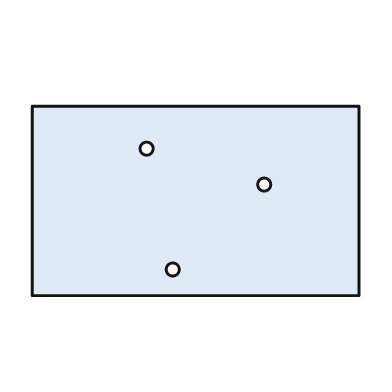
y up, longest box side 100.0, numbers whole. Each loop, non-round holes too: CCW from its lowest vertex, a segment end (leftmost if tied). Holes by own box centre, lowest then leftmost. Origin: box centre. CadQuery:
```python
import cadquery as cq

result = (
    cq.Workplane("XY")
    .moveTo(-50.0, -29.0)
    .lineTo(50.0, -29.0)
    .lineTo(50.0, 29.0)
    .lineTo(-50.0, 29.0)
    .close()
    .moveTo(-7.0, -21.0)
    .circle(2.0)
    .moveTo(21.0, 5.0)
    .circle(2.0)
    .moveTo(-15.0, 16.0)
    .circle(2.0)
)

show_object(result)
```